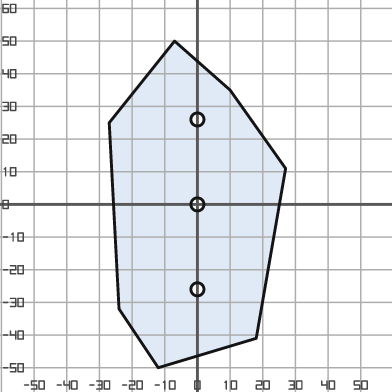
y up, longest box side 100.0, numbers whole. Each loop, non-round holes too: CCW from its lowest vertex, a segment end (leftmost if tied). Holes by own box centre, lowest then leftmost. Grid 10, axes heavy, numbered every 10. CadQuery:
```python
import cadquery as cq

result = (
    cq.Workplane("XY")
    .moveTo(-12.0, -50.0)
    .lineTo(18.0, -41.0)
    .lineTo(27.0, 11.0)
    .lineTo(10.0, 35.0)
    .lineTo(-7.0, 50.0)
    .lineTo(-27.0, 25.0)
    .lineTo(-24.0, -32.0)
    .close()
    .moveTo(0.0, -26.0)
    .circle(2.0)
    .moveTo(0.0, 0.0)
    .circle(2.0)
    .moveTo(0.0, 26.0)
    .circle(2.0)
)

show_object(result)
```